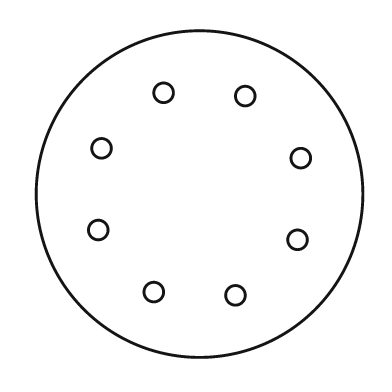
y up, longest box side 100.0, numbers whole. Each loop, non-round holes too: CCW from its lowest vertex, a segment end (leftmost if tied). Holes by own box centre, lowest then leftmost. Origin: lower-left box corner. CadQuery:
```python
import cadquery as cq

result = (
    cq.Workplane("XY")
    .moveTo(50.0, 50.0)
    .circle(50.0)
    .moveTo(61.0, 19.0)
    .circle(3.0)
    .moveTo(36.0, 20.0)
    .circle(3.0)
    .moveTo(80.0, 36.0)
    .circle(3.0)
    .moveTo(19.0, 39.0)
    .circle(3.0)
    .moveTo(81.0, 61.0)
    .circle(3.0)
    .moveTo(20.0, 64.0)
    .circle(3.0)
    .moveTo(64.0, 80.0)
    .circle(3.0)
    .moveTo(39.0, 81.0)
    .circle(3.0)
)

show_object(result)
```